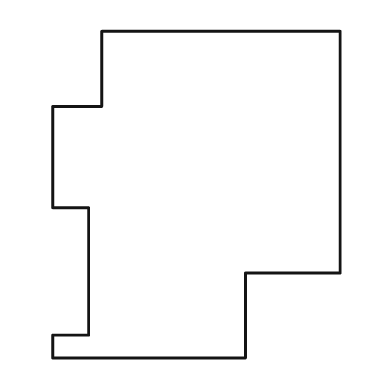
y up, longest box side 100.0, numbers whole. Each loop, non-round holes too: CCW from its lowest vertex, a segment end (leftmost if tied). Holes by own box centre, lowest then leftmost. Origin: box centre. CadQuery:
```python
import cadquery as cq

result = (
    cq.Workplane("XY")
    .moveTo(-44.0, -50.0)
    .lineTo(15.0, -50.0)
    .lineTo(15.0, -24.0)
    .lineTo(44.0, -24.0)
    .lineTo(44.0, 50.0)
    .lineTo(-29.0, 50.0)
    .lineTo(-29.0, 27.0)
    .lineTo(-44.0, 27.0)
    .lineTo(-44.0, -4.0)
    .lineTo(-33.0, -4.0)
    .lineTo(-33.0, -43.0)
    .lineTo(-44.0, -43.0)
    .close()
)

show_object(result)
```